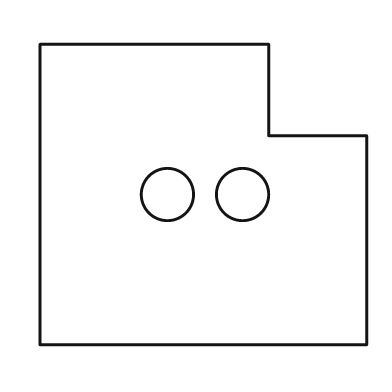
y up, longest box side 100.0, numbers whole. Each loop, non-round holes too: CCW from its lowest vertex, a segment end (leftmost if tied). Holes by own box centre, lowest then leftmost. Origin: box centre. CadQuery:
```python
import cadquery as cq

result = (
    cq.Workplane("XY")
    .moveTo(-50.0, -46.0)
    .lineTo(50.0, -46.0)
    .lineTo(50.0, 18.0)
    .lineTo(20.0, 18.0)
    .lineTo(20.0, 46.0)
    .lineTo(-50.0, 46.0)
    .close()
    .moveTo(-11.0, 0.0)
    .circle(8.0)
    .moveTo(12.0, 0.0)
    .circle(8.0)
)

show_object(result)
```